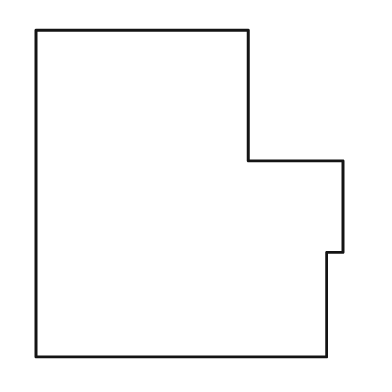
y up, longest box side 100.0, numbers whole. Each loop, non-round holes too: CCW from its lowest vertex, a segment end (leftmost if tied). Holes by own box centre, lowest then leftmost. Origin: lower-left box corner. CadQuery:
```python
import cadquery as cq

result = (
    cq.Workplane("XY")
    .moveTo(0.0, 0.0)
    .lineTo(89.0, 0.0)
    .lineTo(89.0, 32.0)
    .lineTo(94.0, 32.0)
    .lineTo(94.0, 60.0)
    .lineTo(65.0, 60.0)
    .lineTo(65.0, 100.0)
    .lineTo(0.0, 100.0)
    .close()
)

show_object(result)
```